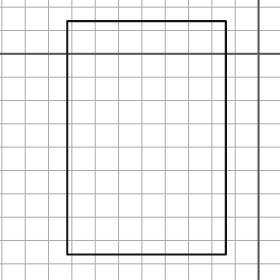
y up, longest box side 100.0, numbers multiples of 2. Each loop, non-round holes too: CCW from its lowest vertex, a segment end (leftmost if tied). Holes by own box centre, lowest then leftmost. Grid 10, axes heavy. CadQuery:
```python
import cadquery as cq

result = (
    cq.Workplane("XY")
    .moveTo(-82.0, -86.0)
    .lineTo(-14.0, -86.0)
    .lineTo(-14.0, 14.0)
    .lineTo(-82.0, 14.0)
    .close()
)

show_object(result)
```